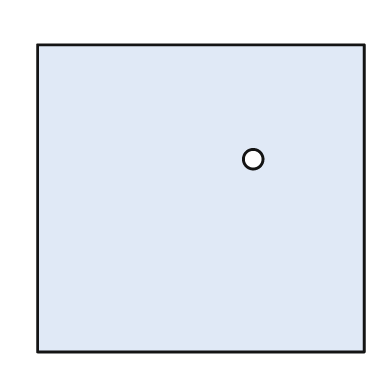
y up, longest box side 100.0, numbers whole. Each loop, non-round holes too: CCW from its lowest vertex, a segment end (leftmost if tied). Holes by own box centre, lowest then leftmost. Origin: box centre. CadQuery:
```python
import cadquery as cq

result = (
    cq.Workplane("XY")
    .moveTo(-50.0, -47.0)
    .lineTo(50.0, -47.0)
    .lineTo(50.0, 47.0)
    .lineTo(-50.0, 47.0)
    .close()
    .moveTo(16.0, 12.0)
    .circle(3.0)
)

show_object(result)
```